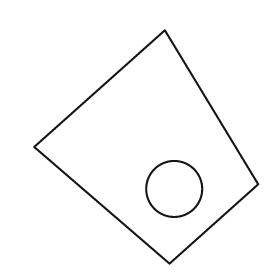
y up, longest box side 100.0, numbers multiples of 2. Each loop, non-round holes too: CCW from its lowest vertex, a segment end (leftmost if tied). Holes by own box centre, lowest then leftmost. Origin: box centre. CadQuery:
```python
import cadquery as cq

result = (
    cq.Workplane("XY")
    .moveTo(10.0, -50.0)
    .lineTo(48.0, -16.0)
    .lineTo(8.0, 50.0)
    .lineTo(-48.0, 0.0)
    .close()
    .moveTo(12.0, -18.0)
    .circle(12.0)
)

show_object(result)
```